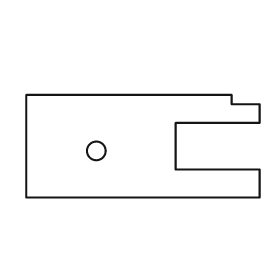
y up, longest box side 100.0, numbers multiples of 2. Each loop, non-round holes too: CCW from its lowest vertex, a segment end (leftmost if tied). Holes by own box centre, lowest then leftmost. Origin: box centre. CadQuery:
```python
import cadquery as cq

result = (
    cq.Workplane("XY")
    .moveTo(-50.0, -22.0)
    .lineTo(50.0, -22.0)
    .lineTo(50.0, -10.0)
    .lineTo(14.0, -10.0)
    .lineTo(14.0, 10.0)
    .lineTo(50.0, 10.0)
    .lineTo(50.0, 18.0)
    .lineTo(38.0, 18.0)
    .lineTo(38.0, 22.0)
    .lineTo(-50.0, 22.0)
    .close()
    .moveTo(-20.0, -2.0)
    .circle(4.0)
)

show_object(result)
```